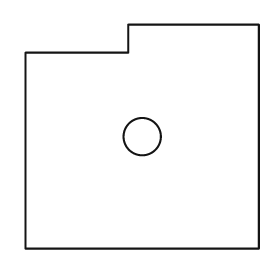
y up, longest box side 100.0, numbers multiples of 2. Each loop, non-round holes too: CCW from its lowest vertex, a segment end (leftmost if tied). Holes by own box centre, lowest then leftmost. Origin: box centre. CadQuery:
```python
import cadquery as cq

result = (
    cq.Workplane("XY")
    .moveTo(-50.0, -48.0)
    .lineTo(50.0, -48.0)
    .lineTo(50.0, 48.0)
    .lineTo(-6.0, 48.0)
    .lineTo(-6.0, 36.0)
    .lineTo(-50.0, 36.0)
    .close()
    .moveTo(0.0, 0.0)
    .circle(8.0)
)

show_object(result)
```